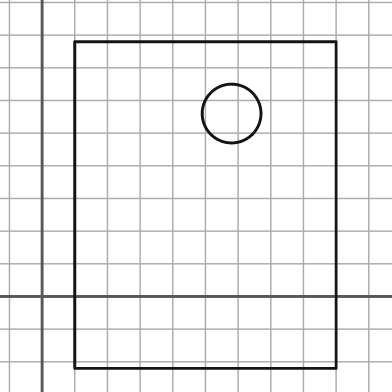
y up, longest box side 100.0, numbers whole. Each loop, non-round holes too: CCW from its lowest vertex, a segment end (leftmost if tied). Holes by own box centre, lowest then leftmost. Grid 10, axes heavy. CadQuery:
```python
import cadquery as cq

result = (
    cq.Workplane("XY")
    .moveTo(10.0, -22.0)
    .lineTo(90.0, -22.0)
    .lineTo(90.0, 78.0)
    .lineTo(10.0, 78.0)
    .close()
    .moveTo(58.0, 56.0)
    .circle(9.0)
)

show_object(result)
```